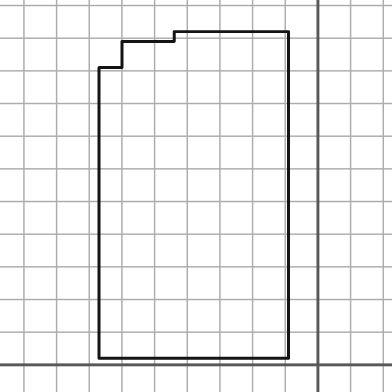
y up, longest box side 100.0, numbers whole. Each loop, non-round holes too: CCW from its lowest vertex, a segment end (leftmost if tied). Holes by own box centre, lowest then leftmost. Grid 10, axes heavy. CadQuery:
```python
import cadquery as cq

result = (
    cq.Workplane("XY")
    .moveTo(-67.0, 2.0)
    .lineTo(-9.0, 2.0)
    .lineTo(-9.0, 102.0)
    .lineTo(-44.0, 102.0)
    .lineTo(-44.0, 99.0)
    .lineTo(-60.0, 99.0)
    .lineTo(-60.0, 91.0)
    .lineTo(-67.0, 91.0)
    .close()
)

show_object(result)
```